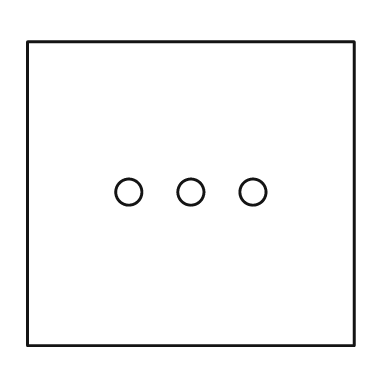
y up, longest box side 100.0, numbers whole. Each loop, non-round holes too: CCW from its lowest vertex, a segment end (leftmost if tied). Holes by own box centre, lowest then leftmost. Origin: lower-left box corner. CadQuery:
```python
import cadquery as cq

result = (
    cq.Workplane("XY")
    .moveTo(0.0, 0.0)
    .lineTo(100.0, 0.0)
    .lineTo(100.0, 93.0)
    .lineTo(0.0, 93.0)
    .close()
    .moveTo(31.0, 47.0)
    .circle(4.0)
    .moveTo(50.0, 47.0)
    .circle(4.0)
    .moveTo(69.0, 47.0)
    .circle(4.0)
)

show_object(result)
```